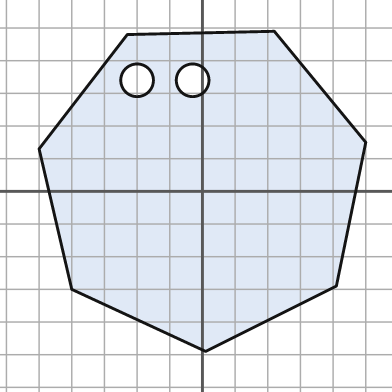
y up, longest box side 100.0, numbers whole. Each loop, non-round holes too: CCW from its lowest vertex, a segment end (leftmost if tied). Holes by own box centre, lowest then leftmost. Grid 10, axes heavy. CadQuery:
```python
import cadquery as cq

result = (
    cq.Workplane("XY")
    .moveTo(1.0, -49.0)
    .lineTo(41.0, -29.0)
    .lineTo(50.0, 15.0)
    .lineTo(22.0, 49.0)
    .lineTo(-23.0, 48.0)
    .lineTo(-50.0, 13.0)
    .lineTo(-40.0, -30.0)
    .close()
    .moveTo(-20.0, 34.0)
    .circle(5.0)
    .moveTo(-3.0, 34.0)
    .circle(5.0)
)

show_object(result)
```